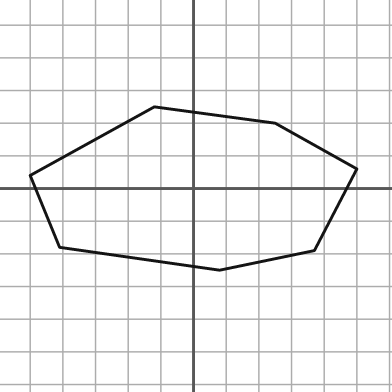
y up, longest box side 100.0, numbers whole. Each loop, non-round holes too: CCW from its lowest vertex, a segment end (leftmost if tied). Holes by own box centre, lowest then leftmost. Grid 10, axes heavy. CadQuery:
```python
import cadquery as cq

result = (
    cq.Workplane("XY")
    .moveTo(8.0, -25.0)
    .lineTo(37.0, -19.0)
    .lineTo(50.0, 6.0)
    .lineTo(25.0, 20.0)
    .lineTo(-12.0, 25.0)
    .lineTo(-50.0, 4.0)
    .lineTo(-41.0, -18.0)
    .close()
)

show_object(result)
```